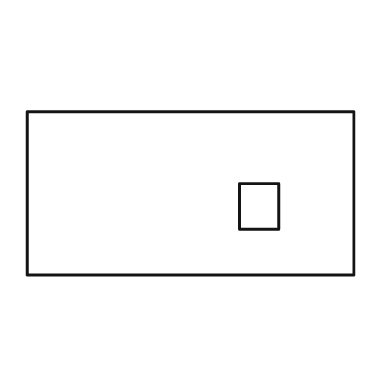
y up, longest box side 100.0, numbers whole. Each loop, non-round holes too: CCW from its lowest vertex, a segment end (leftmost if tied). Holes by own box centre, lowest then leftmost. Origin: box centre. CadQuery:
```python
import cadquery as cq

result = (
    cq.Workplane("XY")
    .moveTo(-50.0, -25.0)
    .lineTo(50.0, -25.0)
    .lineTo(50.0, 25.0)
    .lineTo(-50.0, 25.0)
    .close()
    .moveTo(15.0, -11.0)
    .lineTo(27.0, -11.0)
    .lineTo(27.0, 3.0)
    .lineTo(15.0, 3.0)
    .close()
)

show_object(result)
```